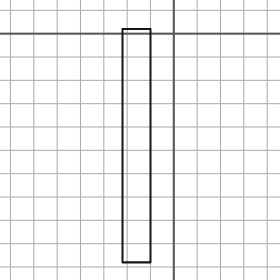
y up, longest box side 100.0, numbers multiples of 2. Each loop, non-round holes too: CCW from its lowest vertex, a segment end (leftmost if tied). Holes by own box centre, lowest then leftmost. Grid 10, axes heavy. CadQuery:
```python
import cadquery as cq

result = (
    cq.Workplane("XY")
    .moveTo(-22.0, -98.0)
    .lineTo(-10.0, -98.0)
    .lineTo(-10.0, 2.0)
    .lineTo(-22.0, 2.0)
    .close()
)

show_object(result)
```